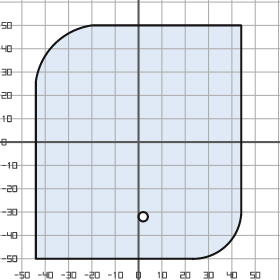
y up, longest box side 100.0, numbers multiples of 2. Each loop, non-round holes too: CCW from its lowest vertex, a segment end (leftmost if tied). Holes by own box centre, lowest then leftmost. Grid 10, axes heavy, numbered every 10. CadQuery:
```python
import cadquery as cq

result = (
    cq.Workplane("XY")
    .moveTo(-44.0, -50.0)
    .lineTo(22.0, -50.0)
    .threePointArc((38.0, -44.0), (44.0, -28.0))
    .lineTo(44.0, 50.0)
    .lineTo(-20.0, 50.0)
    .threePointArc((-36.0, 42.0), (-44.0, 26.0))
    .close()
    .moveTo(2.0, -32.0)
    .circle(2.0)
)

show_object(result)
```